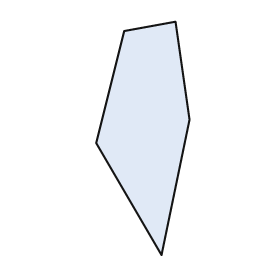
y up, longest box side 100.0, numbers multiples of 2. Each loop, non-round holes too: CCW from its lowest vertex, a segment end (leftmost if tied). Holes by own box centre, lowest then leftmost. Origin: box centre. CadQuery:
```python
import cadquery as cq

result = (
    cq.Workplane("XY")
    .moveTo(8.0, -50.0)
    .lineTo(20.0, 8.0)
    .lineTo(14.0, 50.0)
    .lineTo(-8.0, 46.0)
    .lineTo(-20.0, -2.0)
    .close()
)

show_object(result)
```